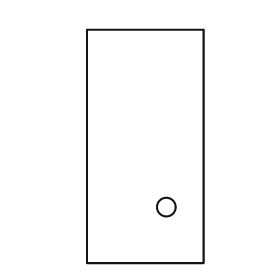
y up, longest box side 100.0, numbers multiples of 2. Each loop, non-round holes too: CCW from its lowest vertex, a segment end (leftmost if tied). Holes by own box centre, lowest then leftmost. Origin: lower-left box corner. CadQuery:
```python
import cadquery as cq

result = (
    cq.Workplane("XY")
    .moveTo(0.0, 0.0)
    .lineTo(50.0, 0.0)
    .lineTo(50.0, 100.0)
    .lineTo(0.0, 100.0)
    .close()
    .moveTo(34.0, 24.0)
    .circle(4.0)
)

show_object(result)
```